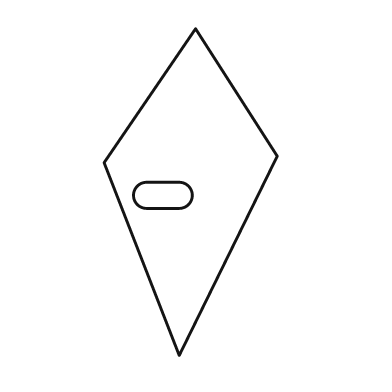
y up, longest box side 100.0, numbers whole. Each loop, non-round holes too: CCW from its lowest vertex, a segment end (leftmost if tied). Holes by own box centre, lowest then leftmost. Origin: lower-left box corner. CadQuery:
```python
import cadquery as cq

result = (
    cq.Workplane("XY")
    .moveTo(23.0, 0.0)
    .lineTo(53.0, 61.0)
    .lineTo(28.0, 100.0)
    .lineTo(0.0, 59.0)
    .close()
    .moveTo(13.0, 45.0)
    .lineTo(23.0, 45.0)
    .threePointArc((27.0, 49.0), (23.0, 53.0))
    .lineTo(13.0, 53.0)
    .threePointArc((9.0, 49.0), (13.0, 45.0))
    .close()
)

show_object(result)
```